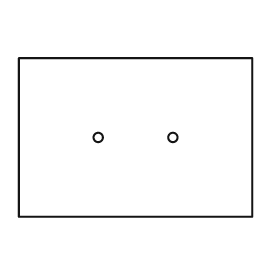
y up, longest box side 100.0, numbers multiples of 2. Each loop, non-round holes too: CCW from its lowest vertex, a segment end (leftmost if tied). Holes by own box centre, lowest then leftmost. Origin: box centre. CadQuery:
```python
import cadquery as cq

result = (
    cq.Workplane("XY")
    .moveTo(-50.0, -34.0)
    .lineTo(50.0, -34.0)
    .lineTo(50.0, 34.0)
    .lineTo(-50.0, 34.0)
    .close()
    .moveTo(-16.0, 0.0)
    .circle(2.0)
    .moveTo(16.0, 0.0)
    .circle(2.0)
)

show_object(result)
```